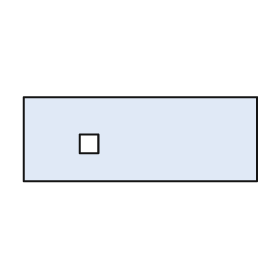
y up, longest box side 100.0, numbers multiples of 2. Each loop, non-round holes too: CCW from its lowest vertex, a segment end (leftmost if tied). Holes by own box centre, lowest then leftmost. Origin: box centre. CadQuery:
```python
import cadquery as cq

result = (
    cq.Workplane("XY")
    .moveTo(-50.0, -18.0)
    .lineTo(50.0, -18.0)
    .lineTo(50.0, 18.0)
    .lineTo(-50.0, 18.0)
    .close()
    .moveTo(-26.0, -6.0)
    .lineTo(-18.0, -6.0)
    .lineTo(-18.0, 2.0)
    .lineTo(-26.0, 2.0)
    .close()
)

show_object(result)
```